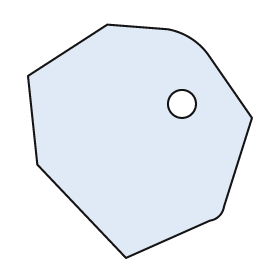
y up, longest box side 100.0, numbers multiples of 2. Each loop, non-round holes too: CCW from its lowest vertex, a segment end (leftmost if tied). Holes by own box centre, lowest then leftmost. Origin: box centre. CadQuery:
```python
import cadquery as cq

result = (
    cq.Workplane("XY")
    .moveTo(-6.0, -50.0)
    .lineTo(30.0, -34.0)
    .threePointArc((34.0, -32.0), (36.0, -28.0))
    .lineTo(48.0, 10.0)
    .lineTo(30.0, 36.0)
    .threePointArc((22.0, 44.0), (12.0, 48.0))
    .lineTo(-14.0, 50.0)
    .lineTo(-48.0, 28.0)
    .lineTo(-44.0, -10.0)
    .close()
    .moveTo(18.0, 16.0)
    .circle(6.0)
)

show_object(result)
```